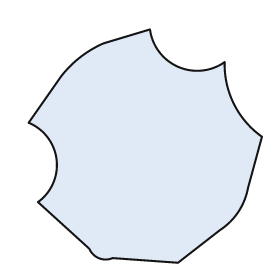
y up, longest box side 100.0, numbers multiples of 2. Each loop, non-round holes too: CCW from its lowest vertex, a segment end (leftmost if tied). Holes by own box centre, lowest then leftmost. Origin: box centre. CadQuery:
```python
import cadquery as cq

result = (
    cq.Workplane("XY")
    .moveTo(14.0, -50.0)
    .lineTo(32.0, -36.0)
    .threePointArc((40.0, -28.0), (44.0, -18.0))
    .lineTo(50.0, 4.0)
    .threePointArc((38.0, 18.0), (34.0, 36.0))
    .threePointArc((14.0, 34.0), (2.0, 50.0))
    .lineTo(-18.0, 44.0)
    .threePointArc((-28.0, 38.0), (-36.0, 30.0))
    .lineTo(-50.0, 10.0)
    .threePointArc((-38.0, -6.0), (-46.0, -24.0))
    .lineTo(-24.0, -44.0)
    .threePointArc((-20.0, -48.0), (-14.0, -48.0))
    .close()
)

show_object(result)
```